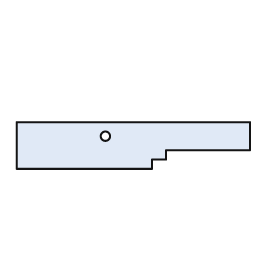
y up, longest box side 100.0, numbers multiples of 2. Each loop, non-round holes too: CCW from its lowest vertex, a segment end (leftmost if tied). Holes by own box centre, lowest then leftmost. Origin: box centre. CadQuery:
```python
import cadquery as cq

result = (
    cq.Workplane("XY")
    .moveTo(-50.0, -10.0)
    .lineTo(8.0, -10.0)
    .lineTo(8.0, -6.0)
    .lineTo(14.0, -6.0)
    .lineTo(14.0, -2.0)
    .lineTo(50.0, -2.0)
    .lineTo(50.0, 10.0)
    .lineTo(-50.0, 10.0)
    .close()
    .moveTo(-12.0, 4.0)
    .circle(2.0)
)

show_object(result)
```